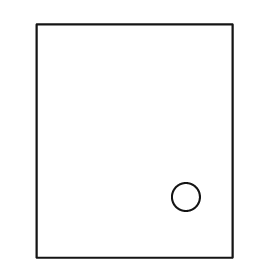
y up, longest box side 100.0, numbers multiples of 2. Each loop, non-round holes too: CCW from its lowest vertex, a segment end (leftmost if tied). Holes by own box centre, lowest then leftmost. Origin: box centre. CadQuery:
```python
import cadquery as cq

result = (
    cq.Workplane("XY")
    .moveTo(-42.0, -50.0)
    .lineTo(42.0, -50.0)
    .lineTo(42.0, 50.0)
    .lineTo(-42.0, 50.0)
    .close()
    .moveTo(22.0, -24.0)
    .circle(6.0)
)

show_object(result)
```